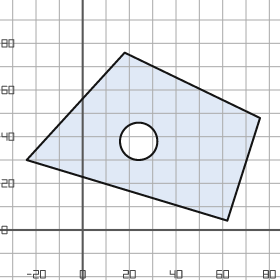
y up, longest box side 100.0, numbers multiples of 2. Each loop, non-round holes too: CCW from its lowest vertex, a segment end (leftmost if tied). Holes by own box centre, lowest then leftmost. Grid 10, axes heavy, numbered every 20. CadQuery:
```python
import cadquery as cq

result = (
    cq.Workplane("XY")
    .moveTo(62.0, 4.0)
    .lineTo(76.0, 48.0)
    .lineTo(18.0, 76.0)
    .lineTo(-24.0, 30.0)
    .close()
    .moveTo(24.0, 38.0)
    .circle(8.0)
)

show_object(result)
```